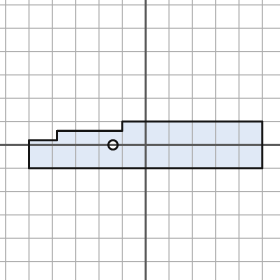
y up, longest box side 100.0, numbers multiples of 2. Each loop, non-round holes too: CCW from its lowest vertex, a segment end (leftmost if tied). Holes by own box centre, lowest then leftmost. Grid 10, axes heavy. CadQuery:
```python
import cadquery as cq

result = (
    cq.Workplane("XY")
    .moveTo(-50.0, -10.0)
    .lineTo(50.0, -10.0)
    .lineTo(50.0, 10.0)
    .lineTo(-10.0, 10.0)
    .lineTo(-10.0, 6.0)
    .lineTo(-38.0, 6.0)
    .lineTo(-38.0, 2.0)
    .lineTo(-50.0, 2.0)
    .close()
    .moveTo(-14.0, 0.0)
    .circle(2.0)
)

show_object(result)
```